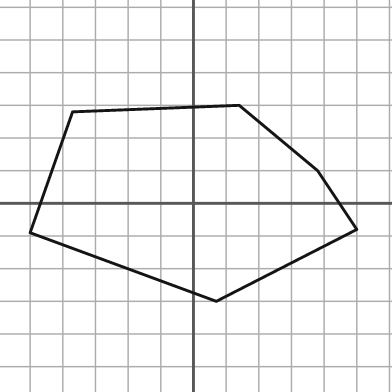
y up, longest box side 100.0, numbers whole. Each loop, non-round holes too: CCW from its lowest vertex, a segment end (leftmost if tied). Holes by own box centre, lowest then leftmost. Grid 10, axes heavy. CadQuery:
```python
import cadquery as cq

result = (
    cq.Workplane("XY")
    .moveTo(7.0, -30.0)
    .lineTo(50.0, -8.0)
    .lineTo(38.0, 10.0)
    .lineTo(14.0, 30.0)
    .lineTo(-37.0, 28.0)
    .lineTo(-50.0, -9.0)
    .close()
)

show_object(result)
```